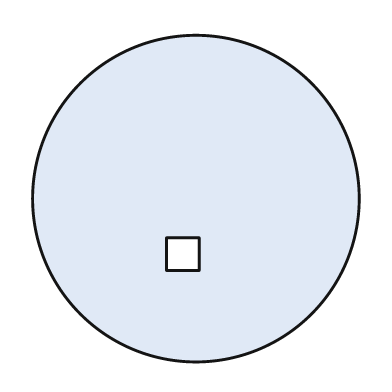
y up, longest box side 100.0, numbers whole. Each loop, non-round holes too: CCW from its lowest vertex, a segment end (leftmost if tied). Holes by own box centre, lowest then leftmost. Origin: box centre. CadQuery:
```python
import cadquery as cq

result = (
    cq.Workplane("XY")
    .moveTo(0.0, 0.0)
    .circle(50.0)
    .moveTo(-9.0, -22.0)
    .lineTo(1.0, -22.0)
    .lineTo(1.0, -12.0)
    .lineTo(-9.0, -12.0)
    .close()
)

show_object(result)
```